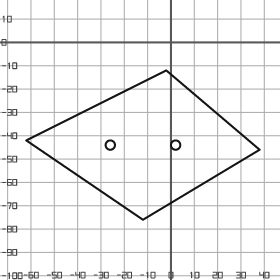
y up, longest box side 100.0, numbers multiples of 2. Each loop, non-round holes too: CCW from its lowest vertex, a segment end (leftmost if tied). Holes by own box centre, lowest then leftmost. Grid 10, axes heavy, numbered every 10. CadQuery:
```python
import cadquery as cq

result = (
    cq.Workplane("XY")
    .moveTo(-12.0, -76.0)
    .lineTo(38.0, -46.0)
    .lineTo(-2.0, -12.0)
    .lineTo(-62.0, -42.0)
    .close()
    .moveTo(-26.0, -44.0)
    .circle(2.0)
    .moveTo(2.0, -44.0)
    .circle(2.0)
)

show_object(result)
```